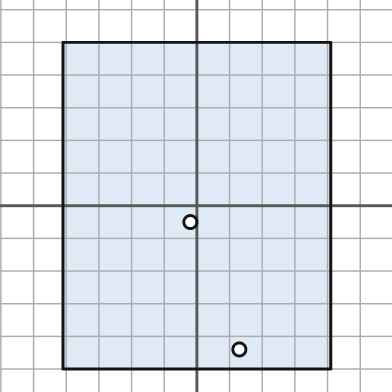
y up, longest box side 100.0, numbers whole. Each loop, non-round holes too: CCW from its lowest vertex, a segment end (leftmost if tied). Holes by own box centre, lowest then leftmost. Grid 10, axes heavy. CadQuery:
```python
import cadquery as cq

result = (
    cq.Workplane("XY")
    .moveTo(-41.0, -50.0)
    .lineTo(41.0, -50.0)
    .lineTo(41.0, 50.0)
    .lineTo(-41.0, 50.0)
    .close()
    .moveTo(13.0, -44.0)
    .circle(2.0)
    .moveTo(-2.0, -5.0)
    .circle(2.0)
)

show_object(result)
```